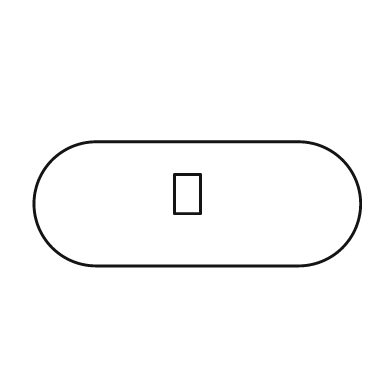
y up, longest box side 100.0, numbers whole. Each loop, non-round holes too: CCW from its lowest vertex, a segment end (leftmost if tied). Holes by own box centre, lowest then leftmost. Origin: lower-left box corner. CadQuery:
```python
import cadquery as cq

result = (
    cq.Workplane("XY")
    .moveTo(19.0, 0.0)
    .lineTo(81.0, 0.0)
    .threePointArc((100.0, 19.0), (81.0, 38.0))
    .lineTo(19.0, 38.0)
    .threePointArc((0.0, 19.0), (19.0, 0.0))
    .close()
    .moveTo(43.0, 16.0)
    .lineTo(51.0, 16.0)
    .lineTo(51.0, 28.0)
    .lineTo(43.0, 28.0)
    .close()
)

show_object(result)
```